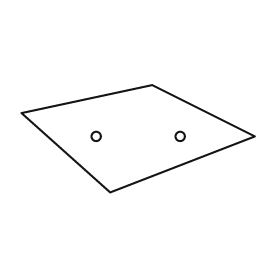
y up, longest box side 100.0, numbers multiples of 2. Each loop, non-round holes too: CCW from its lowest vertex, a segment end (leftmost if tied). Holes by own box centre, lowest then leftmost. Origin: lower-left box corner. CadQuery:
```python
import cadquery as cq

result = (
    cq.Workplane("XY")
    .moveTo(38.0, 0.0)
    .lineTo(100.0, 24.0)
    .lineTo(56.0, 46.0)
    .lineTo(0.0, 34.0)
    .close()
    .moveTo(32.0, 24.0)
    .circle(2.0)
    .moveTo(68.0, 24.0)
    .circle(2.0)
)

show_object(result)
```